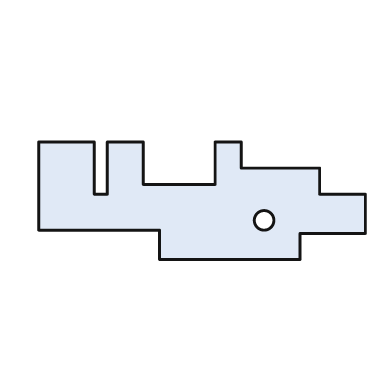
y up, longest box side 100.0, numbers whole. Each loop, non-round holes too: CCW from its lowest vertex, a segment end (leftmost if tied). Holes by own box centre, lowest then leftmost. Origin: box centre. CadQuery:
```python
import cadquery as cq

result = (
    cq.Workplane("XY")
    .moveTo(-13.0, -18.0)
    .lineTo(30.0, -18.0)
    .lineTo(30.0, -10.0)
    .lineTo(50.0, -10.0)
    .lineTo(50.0, 2.0)
    .lineTo(36.0, 2.0)
    .lineTo(36.0, 10.0)
    .lineTo(12.0, 10.0)
    .lineTo(12.0, 18.0)
    .lineTo(4.0, 18.0)
    .lineTo(4.0, 5.0)
    .lineTo(-18.0, 5.0)
    .lineTo(-18.0, 18.0)
    .lineTo(-29.0, 18.0)
    .lineTo(-29.0, 2.0)
    .lineTo(-33.0, 2.0)
    .lineTo(-33.0, 18.0)
    .lineTo(-50.0, 18.0)
    .lineTo(-50.0, -9.0)
    .lineTo(-13.0, -9.0)
    .close()
    .moveTo(19.0, -6.0)
    .circle(3.0)
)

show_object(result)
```